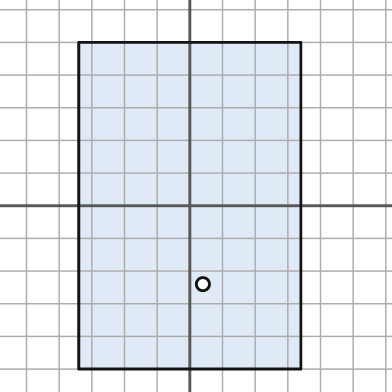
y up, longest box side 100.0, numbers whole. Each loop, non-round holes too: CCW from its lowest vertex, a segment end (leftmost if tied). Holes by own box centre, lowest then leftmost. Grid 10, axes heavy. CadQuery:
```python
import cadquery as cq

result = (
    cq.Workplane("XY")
    .moveTo(-34.0, -50.0)
    .lineTo(34.0, -50.0)
    .lineTo(34.0, 50.0)
    .lineTo(-34.0, 50.0)
    .close()
    .moveTo(4.0, -24.0)
    .circle(2.0)
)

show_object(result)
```